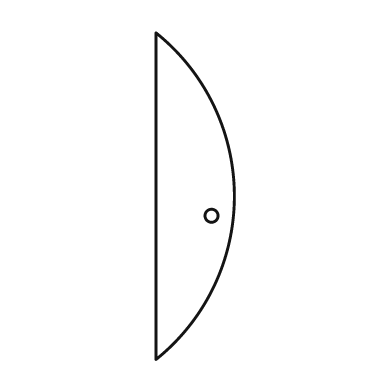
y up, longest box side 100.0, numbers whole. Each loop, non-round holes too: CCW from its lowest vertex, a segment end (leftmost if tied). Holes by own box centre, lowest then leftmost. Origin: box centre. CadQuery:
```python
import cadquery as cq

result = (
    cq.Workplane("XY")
    .moveTo(-12.0, -50.0)
    .threePointArc((12.0, 0.0), (-12.0, 50.0))
    .close()
    .moveTo(5.0, -6.0)
    .circle(2.0)
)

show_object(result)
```